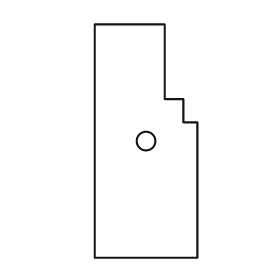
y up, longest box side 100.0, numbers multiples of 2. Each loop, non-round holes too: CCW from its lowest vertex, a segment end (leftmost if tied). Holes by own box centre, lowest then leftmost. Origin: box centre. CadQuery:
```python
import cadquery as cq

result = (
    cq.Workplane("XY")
    .moveTo(-22.0, -50.0)
    .lineTo(22.0, -50.0)
    .lineTo(22.0, 8.0)
    .lineTo(16.0, 8.0)
    .lineTo(16.0, 18.0)
    .lineTo(8.0, 18.0)
    .lineTo(8.0, 50.0)
    .lineTo(-22.0, 50.0)
    .close()
    .moveTo(0.0, 0.0)
    .circle(4.0)
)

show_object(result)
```